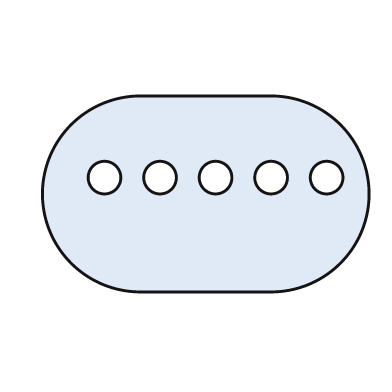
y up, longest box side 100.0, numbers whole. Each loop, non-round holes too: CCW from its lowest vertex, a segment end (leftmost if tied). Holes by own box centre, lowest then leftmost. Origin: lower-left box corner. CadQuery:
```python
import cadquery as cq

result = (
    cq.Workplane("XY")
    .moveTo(30.0, 0.0)
    .lineTo(70.0, 0.0)
    .threePointArc((100.0, 30.0), (70.0, 60.0))
    .lineTo(30.0, 60.0)
    .threePointArc((0.0, 30.0), (30.0, 0.0))
    .close()
    .moveTo(19.0, 35.0)
    .circle(5.0)
    .moveTo(36.0, 35.0)
    .circle(5.0)
    .moveTo(53.0, 35.0)
    .circle(5.0)
    .moveTo(70.0, 35.0)
    .circle(5.0)
    .moveTo(87.0, 35.0)
    .circle(5.0)
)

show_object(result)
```